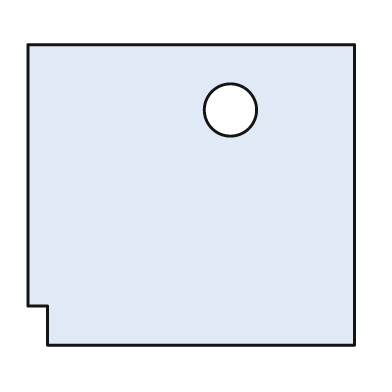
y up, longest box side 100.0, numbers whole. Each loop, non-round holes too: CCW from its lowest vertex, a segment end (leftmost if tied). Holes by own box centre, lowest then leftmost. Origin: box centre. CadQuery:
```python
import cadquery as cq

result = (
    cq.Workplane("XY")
    .moveTo(-44.0, -46.0)
    .lineTo(50.0, -46.0)
    .lineTo(50.0, 46.0)
    .lineTo(-50.0, 46.0)
    .lineTo(-50.0, -34.0)
    .lineTo(-44.0, -34.0)
    .close()
    .moveTo(12.0, 26.0)
    .circle(8.0)
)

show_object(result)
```